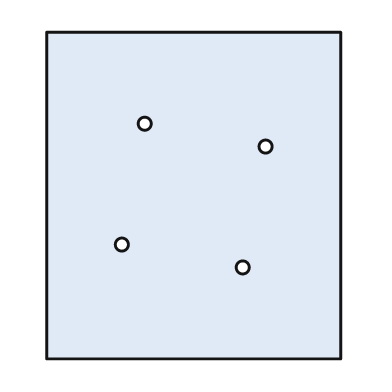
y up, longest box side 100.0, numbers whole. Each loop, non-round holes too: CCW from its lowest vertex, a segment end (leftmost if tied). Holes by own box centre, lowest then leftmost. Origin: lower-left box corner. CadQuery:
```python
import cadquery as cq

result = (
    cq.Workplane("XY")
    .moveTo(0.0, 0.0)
    .lineTo(90.0, 0.0)
    .lineTo(90.0, 100.0)
    .lineTo(0.0, 100.0)
    .close()
    .moveTo(60.0, 28.0)
    .circle(2.0)
    .moveTo(23.0, 35.0)
    .circle(2.0)
    .moveTo(67.0, 65.0)
    .circle(2.0)
    .moveTo(30.0, 72.0)
    .circle(2.0)
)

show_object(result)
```